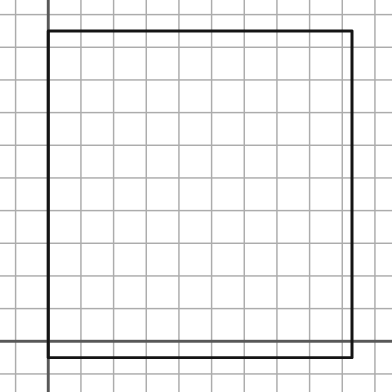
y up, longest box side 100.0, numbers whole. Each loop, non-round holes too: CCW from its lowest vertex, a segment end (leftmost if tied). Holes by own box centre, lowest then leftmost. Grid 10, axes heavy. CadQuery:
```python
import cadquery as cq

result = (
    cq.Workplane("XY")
    .moveTo(0.0, -5.0)
    .lineTo(93.0, -5.0)
    .lineTo(93.0, 95.0)
    .lineTo(0.0, 95.0)
    .close()
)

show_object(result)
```